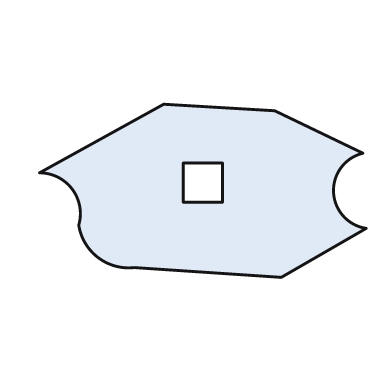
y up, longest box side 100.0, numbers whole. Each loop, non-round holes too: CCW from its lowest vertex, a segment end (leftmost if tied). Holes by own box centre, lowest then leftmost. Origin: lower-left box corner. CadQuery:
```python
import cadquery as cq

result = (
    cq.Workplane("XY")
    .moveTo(74.0, 0.0)
    .lineTo(100.0, 15.0)
    .threePointArc((90.0, 26.0), (99.0, 38.0))
    .lineTo(72.0, 51.0)
    .lineTo(38.0, 53.0)
    .lineTo(0.0, 32.0)
    .threePointArc((10.0, 27.0), (12.0, 16.0))
    .threePointArc((18.0, 6.0), (29.0, 3.0))
    .close()
    .moveTo(44.0, 23.0)
    .lineTo(56.0, 23.0)
    .lineTo(56.0, 35.0)
    .lineTo(44.0, 35.0)
    .close()
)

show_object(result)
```